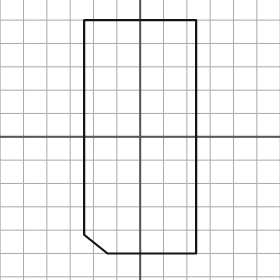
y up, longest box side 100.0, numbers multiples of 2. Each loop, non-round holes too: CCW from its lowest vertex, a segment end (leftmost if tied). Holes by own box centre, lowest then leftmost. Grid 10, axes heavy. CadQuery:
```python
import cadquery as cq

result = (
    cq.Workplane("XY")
    .moveTo(-14.0, -50.0)
    .lineTo(24.0, -50.0)
    .lineTo(24.0, 50.0)
    .lineTo(-24.0, 50.0)
    .lineTo(-24.0, -42.0)
    .close()
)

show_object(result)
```